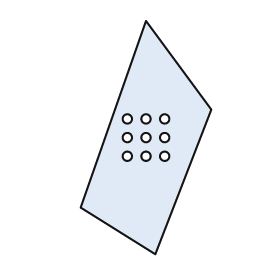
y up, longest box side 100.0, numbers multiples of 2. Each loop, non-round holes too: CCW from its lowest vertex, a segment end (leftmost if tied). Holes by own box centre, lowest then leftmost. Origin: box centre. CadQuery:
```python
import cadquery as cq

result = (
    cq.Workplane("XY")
    .moveTo(4.0, -50.0)
    .lineTo(28.0, 12.0)
    .lineTo(0.0, 50.0)
    .lineTo(-28.0, -30.0)
    .close()
    .moveTo(-8.0, -8.0)
    .circle(2.0)
    .moveTo(0.0, -8.0)
    .circle(2.0)
    .moveTo(8.0, -8.0)
    .circle(2.0)
    .moveTo(-8.0, 0.0)
    .circle(2.0)
    .moveTo(0.0, 0.0)
    .circle(2.0)
    .moveTo(8.0, 0.0)
    .circle(2.0)
    .moveTo(-8.0, 8.0)
    .circle(2.0)
    .moveTo(0.0, 8.0)
    .circle(2.0)
    .moveTo(8.0, 8.0)
    .circle(2.0)
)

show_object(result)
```